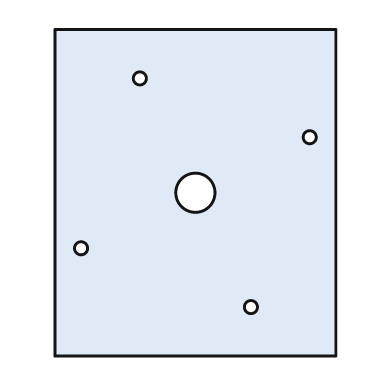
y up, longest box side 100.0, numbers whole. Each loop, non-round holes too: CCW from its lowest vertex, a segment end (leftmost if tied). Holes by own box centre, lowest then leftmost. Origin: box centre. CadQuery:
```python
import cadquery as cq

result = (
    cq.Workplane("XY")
    .moveTo(-43.0, -50.0)
    .lineTo(43.0, -50.0)
    .lineTo(43.0, 50.0)
    .lineTo(-43.0, 50.0)
    .close()
    .moveTo(17.0, -35.0)
    .circle(2.0)
    .moveTo(-35.0, -17.0)
    .circle(2.0)
    .moveTo(0.0, 0.0)
    .circle(6.0)
    .moveTo(35.0, 17.0)
    .circle(2.0)
    .moveTo(-17.0, 35.0)
    .circle(2.0)
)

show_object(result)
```